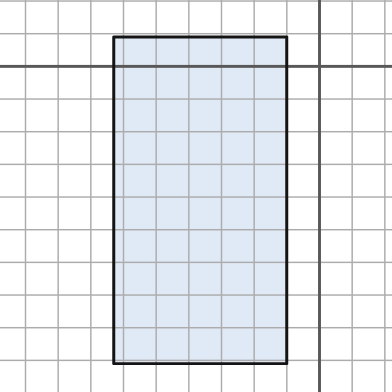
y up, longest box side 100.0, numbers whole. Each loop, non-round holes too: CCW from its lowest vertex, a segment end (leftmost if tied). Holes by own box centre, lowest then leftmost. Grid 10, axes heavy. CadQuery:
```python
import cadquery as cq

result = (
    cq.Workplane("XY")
    .moveTo(-63.0, -91.0)
    .lineTo(-10.0, -91.0)
    .lineTo(-10.0, 9.0)
    .lineTo(-63.0, 9.0)
    .close()
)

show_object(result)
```